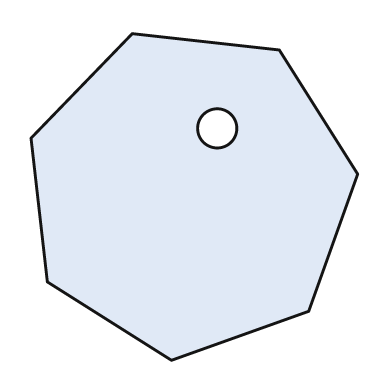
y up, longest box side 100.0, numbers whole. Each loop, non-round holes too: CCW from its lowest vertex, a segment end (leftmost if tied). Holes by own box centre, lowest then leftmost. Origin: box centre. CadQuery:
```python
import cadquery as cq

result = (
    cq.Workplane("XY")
    .moveTo(-7.0, -50.0)
    .lineTo(35.0, -35.0)
    .lineTo(50.0, 7.0)
    .lineTo(26.0, 45.0)
    .lineTo(-19.0, 50.0)
    .lineTo(-50.0, 18.0)
    .lineTo(-45.0, -26.0)
    .close()
    .moveTo(7.0, 21.0)
    .circle(6.0)
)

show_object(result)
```